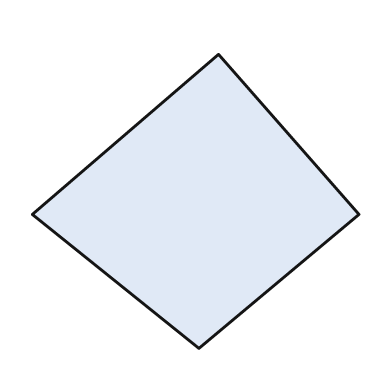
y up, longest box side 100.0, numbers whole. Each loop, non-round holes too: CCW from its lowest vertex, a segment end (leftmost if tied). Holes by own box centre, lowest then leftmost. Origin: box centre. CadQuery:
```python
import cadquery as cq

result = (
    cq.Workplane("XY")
    .moveTo(1.0, -45.0)
    .lineTo(50.0, -4.0)
    .lineTo(7.0, 45.0)
    .lineTo(-50.0, -4.0)
    .close()
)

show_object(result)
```